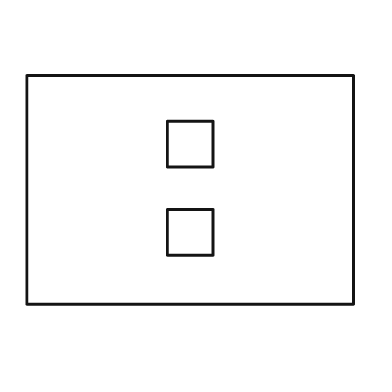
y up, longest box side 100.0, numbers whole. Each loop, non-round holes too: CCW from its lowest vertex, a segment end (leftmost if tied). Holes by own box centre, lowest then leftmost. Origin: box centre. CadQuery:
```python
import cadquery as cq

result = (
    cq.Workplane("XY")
    .moveTo(-50.0, -35.0)
    .lineTo(50.0, -35.0)
    .lineTo(50.0, 35.0)
    .lineTo(-50.0, 35.0)
    .close()
    .moveTo(-7.0, -20.0)
    .lineTo(7.0, -20.0)
    .lineTo(7.0, -6.0)
    .lineTo(-7.0, -6.0)
    .close()
    .moveTo(-7.0, 7.0)
    .lineTo(7.0, 7.0)
    .lineTo(7.0, 21.0)
    .lineTo(-7.0, 21.0)
    .close()
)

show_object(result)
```